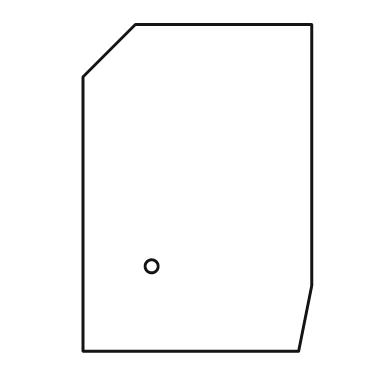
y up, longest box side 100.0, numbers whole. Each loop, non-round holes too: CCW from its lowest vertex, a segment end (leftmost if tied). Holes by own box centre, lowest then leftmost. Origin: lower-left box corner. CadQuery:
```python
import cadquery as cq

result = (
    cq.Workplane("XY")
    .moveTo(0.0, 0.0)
    .lineTo(66.0, 0.0)
    .lineTo(70.0, 20.0)
    .lineTo(70.0, 100.0)
    .lineTo(16.0, 100.0)
    .lineTo(0.0, 84.0)
    .close()
    .moveTo(21.0, 26.0)
    .circle(2.0)
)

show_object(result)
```